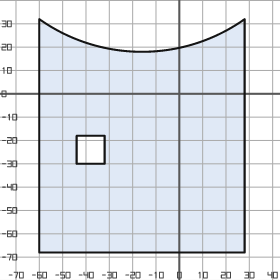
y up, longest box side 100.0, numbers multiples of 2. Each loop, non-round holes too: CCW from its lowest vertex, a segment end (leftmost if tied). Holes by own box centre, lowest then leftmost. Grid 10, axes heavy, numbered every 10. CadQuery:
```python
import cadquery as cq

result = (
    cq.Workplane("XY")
    .moveTo(-60.0, -68.0)
    .lineTo(28.0, -68.0)
    .lineTo(28.0, 32.0)
    .threePointArc((-16.0, 18.0), (-60.0, 32.0))
    .close()
    .moveTo(-44.0, -30.0)
    .lineTo(-32.0, -30.0)
    .lineTo(-32.0, -18.0)
    .lineTo(-44.0, -18.0)
    .close()
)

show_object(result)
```